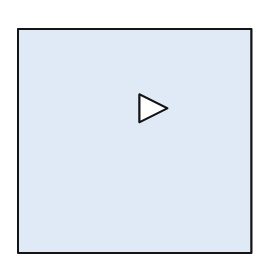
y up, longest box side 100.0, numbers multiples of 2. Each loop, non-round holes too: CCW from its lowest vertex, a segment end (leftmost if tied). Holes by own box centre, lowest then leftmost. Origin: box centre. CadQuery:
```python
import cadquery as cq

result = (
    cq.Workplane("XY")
    .moveTo(-50.0, -48.0)
    .lineTo(50.0, -48.0)
    .lineTo(50.0, 48.0)
    .lineTo(-50.0, 48.0)
    .close()
    .moveTo(2.0, 8.0)
    .lineTo(14.0, 14.0)
    .lineTo(2.0, 20.0)
    .close()
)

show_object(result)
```